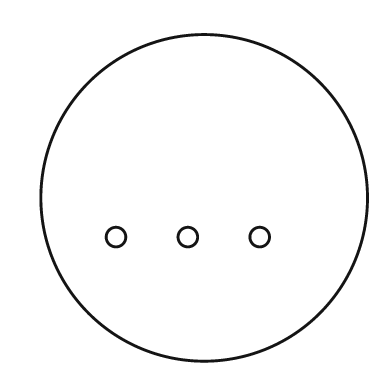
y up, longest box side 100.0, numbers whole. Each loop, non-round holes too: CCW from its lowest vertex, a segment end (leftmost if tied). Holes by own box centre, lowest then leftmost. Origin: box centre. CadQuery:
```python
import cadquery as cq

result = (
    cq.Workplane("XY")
    .moveTo(0.0, 0.0)
    .circle(50.0)
    .moveTo(-27.0, -12.0)
    .circle(3.0)
    .moveTo(-5.0, -12.0)
    .circle(3.0)
    .moveTo(17.0, -12.0)
    .circle(3.0)
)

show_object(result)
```